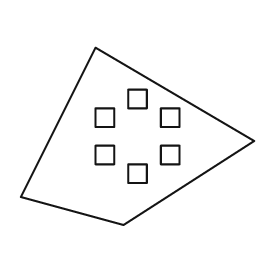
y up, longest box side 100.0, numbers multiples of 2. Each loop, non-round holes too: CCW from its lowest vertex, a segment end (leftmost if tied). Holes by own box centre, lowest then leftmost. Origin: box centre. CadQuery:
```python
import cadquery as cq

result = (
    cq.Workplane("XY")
    .moveTo(-6.0, -38.0)
    .lineTo(50.0, -2.0)
    .lineTo(-18.0, 38.0)
    .lineTo(-50.0, -26.0)
    .close()
    .moveTo(-4.0, -20.0)
    .lineTo(4.0, -20.0)
    .lineTo(4.0, -12.0)
    .lineTo(-4.0, -12.0)
    .close()
    .moveTo(-18.0, -12.0)
    .lineTo(-10.0, -12.0)
    .lineTo(-10.0, -4.0)
    .lineTo(-18.0, -4.0)
    .close()
    .moveTo(10.0, -12.0)
    .lineTo(18.0, -12.0)
    .lineTo(18.0, -4.0)
    .lineTo(10.0, -4.0)
    .close()
    .moveTo(-18.0, 4.0)
    .lineTo(-10.0, 4.0)
    .lineTo(-10.0, 12.0)
    .lineTo(-18.0, 12.0)
    .close()
    .moveTo(10.0, 4.0)
    .lineTo(18.0, 4.0)
    .lineTo(18.0, 12.0)
    .lineTo(10.0, 12.0)
    .close()
    .moveTo(-4.0, 12.0)
    .lineTo(4.0, 12.0)
    .lineTo(4.0, 20.0)
    .lineTo(-4.0, 20.0)
    .close()
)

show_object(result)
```